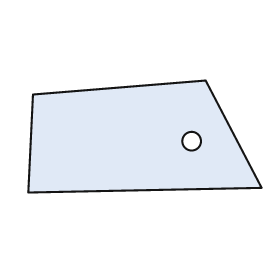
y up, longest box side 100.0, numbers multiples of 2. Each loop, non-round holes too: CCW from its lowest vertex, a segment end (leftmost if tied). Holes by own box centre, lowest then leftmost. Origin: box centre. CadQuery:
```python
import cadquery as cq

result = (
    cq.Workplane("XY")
    .moveTo(-50.0, -24.0)
    .lineTo(50.0, -22.0)
    .lineTo(26.0, 24.0)
    .lineTo(-48.0, 18.0)
    .close()
    .moveTo(20.0, -2.0)
    .circle(4.0)
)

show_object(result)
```